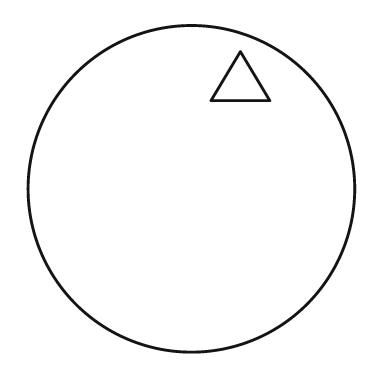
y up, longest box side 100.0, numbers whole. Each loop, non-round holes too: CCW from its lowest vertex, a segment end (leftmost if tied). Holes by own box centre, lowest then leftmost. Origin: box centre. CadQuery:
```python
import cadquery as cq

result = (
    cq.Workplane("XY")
    .moveTo(0.0, 0.0)
    .circle(50.0)
    .moveTo(6.0, 27.0)
    .lineTo(24.0, 27.0)
    .lineTo(15.0, 42.0)
    .close()
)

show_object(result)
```